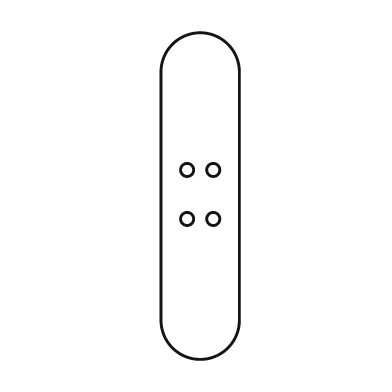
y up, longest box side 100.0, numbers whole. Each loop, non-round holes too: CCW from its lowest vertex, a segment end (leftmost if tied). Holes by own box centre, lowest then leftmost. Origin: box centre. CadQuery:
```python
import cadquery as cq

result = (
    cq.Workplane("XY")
    .moveTo(-12.0, -38.0)
    .threePointArc((0.0, -50.0), (12.0, -38.0))
    .lineTo(12.0, 38.0)
    .threePointArc((0.0, 50.0), (-12.0, 38.0))
    .close()
    .moveTo(-4.0, -7.0)
    .circle(2.0)
    .moveTo(4.0, -7.0)
    .circle(2.0)
    .moveTo(-4.0, 8.0)
    .circle(2.0)
    .moveTo(4.0, 8.0)
    .circle(2.0)
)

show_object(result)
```